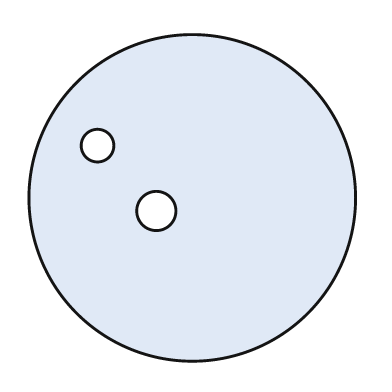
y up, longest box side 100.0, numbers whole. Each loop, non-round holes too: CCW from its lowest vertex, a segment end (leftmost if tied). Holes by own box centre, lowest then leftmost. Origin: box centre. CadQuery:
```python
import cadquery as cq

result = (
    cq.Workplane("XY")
    .moveTo(0.0, 0.0)
    .circle(50.0)
    .moveTo(-11.0, -4.0)
    .circle(6.0)
    .moveTo(-29.0, 16.0)
    .circle(5.0)
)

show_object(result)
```